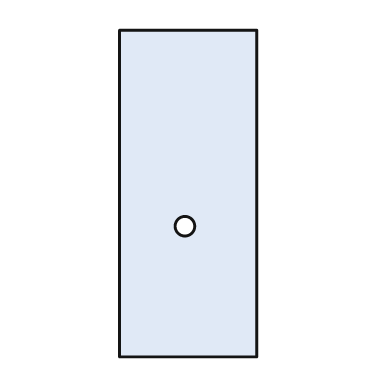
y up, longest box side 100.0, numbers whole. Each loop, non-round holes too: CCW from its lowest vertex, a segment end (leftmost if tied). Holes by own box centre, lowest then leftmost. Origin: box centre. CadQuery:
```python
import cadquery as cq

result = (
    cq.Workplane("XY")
    .moveTo(-21.0, -50.0)
    .lineTo(21.0, -50.0)
    .lineTo(21.0, 50.0)
    .lineTo(-21.0, 50.0)
    .close()
    .moveTo(-1.0, -10.0)
    .circle(3.0)
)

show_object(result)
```